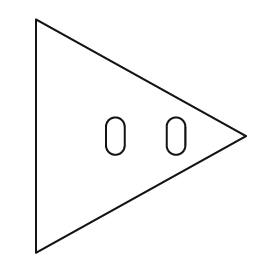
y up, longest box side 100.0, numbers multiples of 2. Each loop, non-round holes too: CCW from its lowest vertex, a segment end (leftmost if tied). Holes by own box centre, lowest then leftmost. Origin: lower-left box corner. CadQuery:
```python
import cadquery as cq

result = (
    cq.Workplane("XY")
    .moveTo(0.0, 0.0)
    .lineTo(90.0, 50.0)
    .lineTo(0.0, 100.0)
    .close()
    .moveTo(30.0, 46.0)
    .threePointArc((34.0, 42.0), (38.0, 46.0))
    .lineTo(38.0, 54.0)
    .threePointArc((34.0, 58.0), (30.0, 54.0))
    .close()
    .moveTo(56.0, 46.0)
    .threePointArc((60.0, 42.0), (64.0, 46.0))
    .lineTo(64.0, 54.0)
    .threePointArc((60.0, 58.0), (56.0, 54.0))
    .close()
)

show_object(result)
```